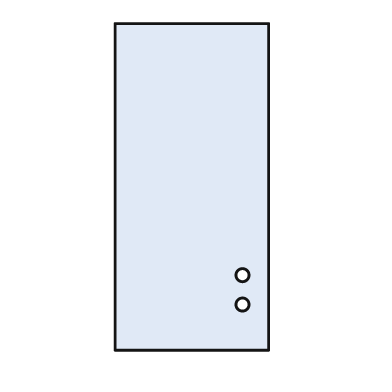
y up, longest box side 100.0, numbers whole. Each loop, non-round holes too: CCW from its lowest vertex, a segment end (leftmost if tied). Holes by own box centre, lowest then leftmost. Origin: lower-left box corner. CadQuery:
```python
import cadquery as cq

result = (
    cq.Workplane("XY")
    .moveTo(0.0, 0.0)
    .lineTo(47.0, 0.0)
    .lineTo(47.0, 100.0)
    .lineTo(0.0, 100.0)
    .close()
    .moveTo(39.0, 14.0)
    .circle(2.0)
    .moveTo(39.0, 23.0)
    .circle(2.0)
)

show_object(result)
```